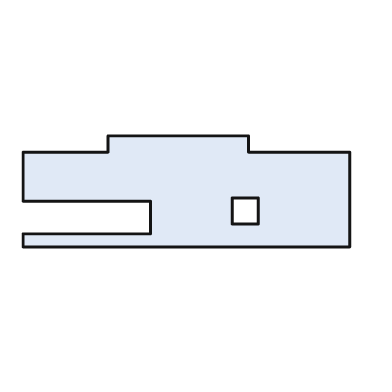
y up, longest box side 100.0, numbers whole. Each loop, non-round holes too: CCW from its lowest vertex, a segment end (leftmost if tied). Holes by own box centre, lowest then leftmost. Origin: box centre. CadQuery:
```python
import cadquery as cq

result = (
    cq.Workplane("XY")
    .moveTo(-50.0, -17.0)
    .lineTo(50.0, -17.0)
    .lineTo(50.0, 12.0)
    .lineTo(19.0, 12.0)
    .lineTo(19.0, 17.0)
    .lineTo(-24.0, 17.0)
    .lineTo(-24.0, 12.0)
    .lineTo(-50.0, 12.0)
    .lineTo(-50.0, -3.0)
    .lineTo(-11.0, -3.0)
    .lineTo(-11.0, -13.0)
    .lineTo(-50.0, -13.0)
    .close()
    .moveTo(14.0, -10.0)
    .lineTo(22.0, -10.0)
    .lineTo(22.0, -2.0)
    .lineTo(14.0, -2.0)
    .close()
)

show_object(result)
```